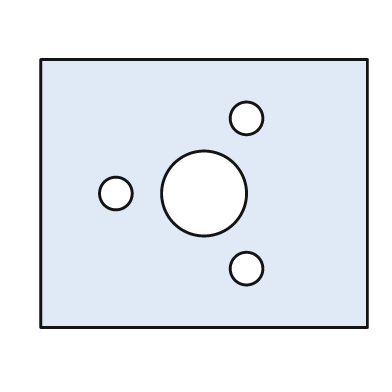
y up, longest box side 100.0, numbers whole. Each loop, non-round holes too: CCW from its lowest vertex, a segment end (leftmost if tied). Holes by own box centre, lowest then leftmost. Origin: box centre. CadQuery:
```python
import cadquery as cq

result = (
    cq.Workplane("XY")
    .moveTo(-50.0, -41.0)
    .lineTo(50.0, -41.0)
    .lineTo(50.0, 41.0)
    .lineTo(-50.0, 41.0)
    .close()
    .moveTo(13.0, -23.0)
    .circle(5.0)
    .moveTo(-27.0, 0.0)
    .circle(5.0)
    .moveTo(0.0, 0.0)
    .circle(13.0)
    .moveTo(13.0, 23.0)
    .circle(5.0)
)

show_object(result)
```